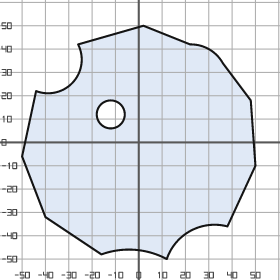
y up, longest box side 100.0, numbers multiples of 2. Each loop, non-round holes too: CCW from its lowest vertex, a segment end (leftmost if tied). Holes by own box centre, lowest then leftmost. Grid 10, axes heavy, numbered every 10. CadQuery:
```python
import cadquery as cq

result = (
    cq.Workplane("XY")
    .moveTo(12.0, -50.0)
    .threePointArc((22.0, -38.0), (38.0, -36.0))
    .lineTo(50.0, -10.0)
    .lineTo(48.0, 18.0)
    .lineTo(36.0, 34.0)
    .threePointArc((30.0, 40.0), (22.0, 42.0))
    .lineTo(2.0, 50.0)
    .lineTo(-26.0, 42.0)
    .threePointArc((-28.0, 26.0), (-44.0, 22.0))
    .lineTo(-50.0, -6.0)
    .lineTo(-40.0, -32.0)
    .lineTo(-16.0, -48.0)
    .threePointArc((-2.0, -46.0), (12.0, -50.0))
    .close()
    .moveTo(-12.0, 12.0)
    .circle(6.0)
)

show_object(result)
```